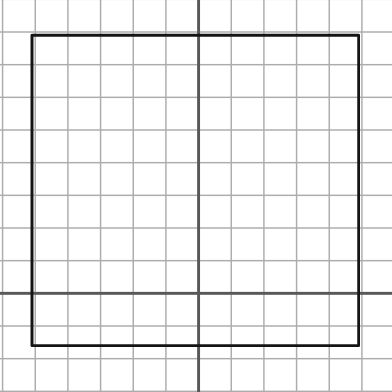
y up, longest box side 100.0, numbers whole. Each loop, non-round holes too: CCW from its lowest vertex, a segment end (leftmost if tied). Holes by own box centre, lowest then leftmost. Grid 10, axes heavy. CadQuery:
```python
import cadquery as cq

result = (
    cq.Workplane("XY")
    .moveTo(-51.0, -16.0)
    .lineTo(49.0, -16.0)
    .lineTo(49.0, 79.0)
    .lineTo(-51.0, 79.0)
    .close()
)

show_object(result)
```